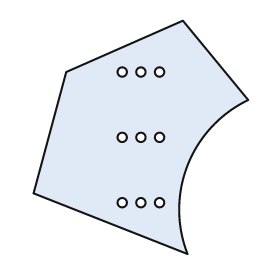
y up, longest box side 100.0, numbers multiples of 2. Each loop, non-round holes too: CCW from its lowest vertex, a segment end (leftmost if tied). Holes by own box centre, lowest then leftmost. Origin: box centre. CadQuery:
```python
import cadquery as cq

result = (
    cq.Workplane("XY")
    .moveTo(20.0, -50.0)
    .threePointArc((20.0, -12.0), (46.0, 16.0))
    .lineTo(18.0, 50.0)
    .lineTo(-32.0, 28.0)
    .lineTo(-46.0, -24.0)
    .close()
    .moveTo(-8.0, -28.0)
    .circle(2.0)
    .moveTo(0.0, -28.0)
    .circle(2.0)
    .moveTo(8.0, -28.0)
    .circle(2.0)
    .moveTo(-8.0, 0.0)
    .circle(2.0)
    .moveTo(0.0, 0.0)
    .circle(2.0)
    .moveTo(8.0, 0.0)
    .circle(2.0)
    .moveTo(-8.0, 28.0)
    .circle(2.0)
    .moveTo(0.0, 28.0)
    .circle(2.0)
    .moveTo(8.0, 28.0)
    .circle(2.0)
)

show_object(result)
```